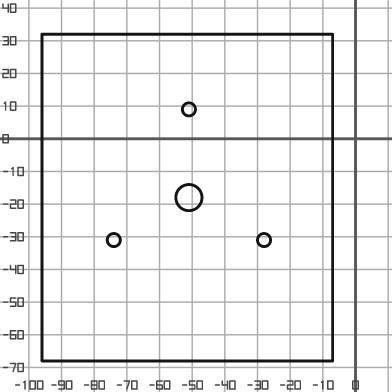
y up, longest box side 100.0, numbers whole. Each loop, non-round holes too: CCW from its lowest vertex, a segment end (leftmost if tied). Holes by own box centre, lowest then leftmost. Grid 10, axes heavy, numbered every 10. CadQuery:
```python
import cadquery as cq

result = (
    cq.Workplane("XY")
    .moveTo(-96.0, -68.0)
    .lineTo(-7.0, -68.0)
    .lineTo(-7.0, 32.0)
    .lineTo(-96.0, 32.0)
    .close()
    .moveTo(-74.0, -31.0)
    .circle(2.0)
    .moveTo(-28.0, -31.0)
    .circle(2.0)
    .moveTo(-51.0, -18.0)
    .circle(4.0)
    .moveTo(-51.0, 9.0)
    .circle(2.0)
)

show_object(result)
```